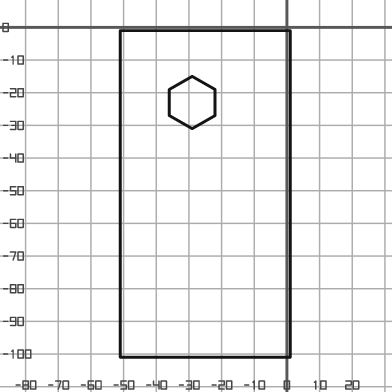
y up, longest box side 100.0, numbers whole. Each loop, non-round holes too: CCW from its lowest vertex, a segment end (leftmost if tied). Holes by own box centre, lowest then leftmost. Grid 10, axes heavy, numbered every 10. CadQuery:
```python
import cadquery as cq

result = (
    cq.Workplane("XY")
    .moveTo(-51.0, -101.0)
    .lineTo(1.0, -101.0)
    .lineTo(1.0, -1.0)
    .lineTo(-51.0, -1.0)
    .close()
    .moveTo(-29.0, -31.0)
    .lineTo(-22.0, -27.0)
    .lineTo(-22.0, -19.0)
    .lineTo(-29.0, -15.0)
    .lineTo(-36.0, -19.0)
    .lineTo(-36.0, -27.0)
    .close()
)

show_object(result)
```